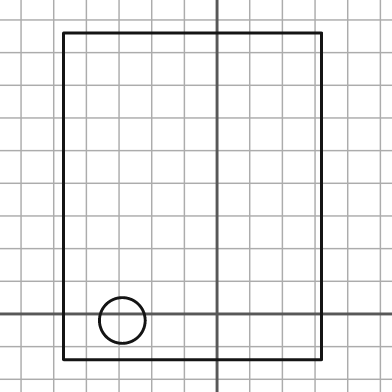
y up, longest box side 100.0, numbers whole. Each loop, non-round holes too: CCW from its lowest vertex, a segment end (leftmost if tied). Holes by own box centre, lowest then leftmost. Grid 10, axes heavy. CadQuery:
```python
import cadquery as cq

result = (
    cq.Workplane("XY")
    .moveTo(-47.0, -14.0)
    .lineTo(32.0, -14.0)
    .lineTo(32.0, 86.0)
    .lineTo(-47.0, 86.0)
    .close()
    .moveTo(-29.0, -2.0)
    .circle(7.0)
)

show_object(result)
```